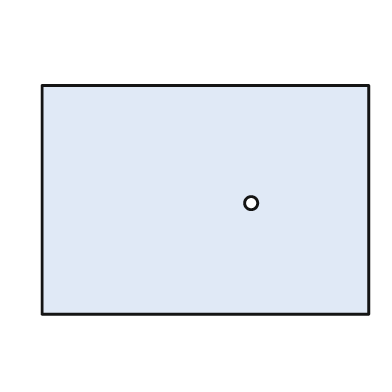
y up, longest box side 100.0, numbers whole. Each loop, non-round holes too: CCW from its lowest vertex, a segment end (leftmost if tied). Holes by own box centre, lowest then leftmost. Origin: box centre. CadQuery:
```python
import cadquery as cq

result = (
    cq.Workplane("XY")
    .moveTo(-50.0, -35.0)
    .lineTo(50.0, -35.0)
    .lineTo(50.0, 35.0)
    .lineTo(-50.0, 35.0)
    .close()
    .moveTo(14.0, -1.0)
    .circle(2.0)
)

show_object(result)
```